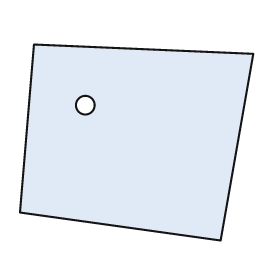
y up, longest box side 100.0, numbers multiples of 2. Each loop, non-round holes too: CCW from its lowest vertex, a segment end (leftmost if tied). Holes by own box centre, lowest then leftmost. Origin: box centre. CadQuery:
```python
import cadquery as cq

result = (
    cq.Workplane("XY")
    .moveTo(36.0, -42.0)
    .lineTo(50.0, 38.0)
    .lineTo(-44.0, 42.0)
    .lineTo(-50.0, -30.0)
    .close()
    .moveTo(-22.0, 16.0)
    .circle(4.0)
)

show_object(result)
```